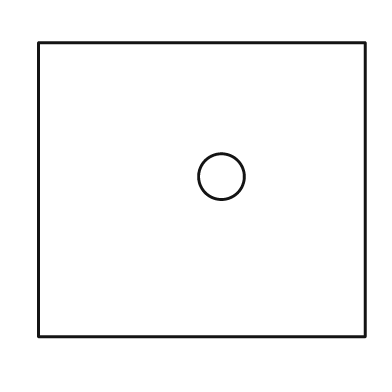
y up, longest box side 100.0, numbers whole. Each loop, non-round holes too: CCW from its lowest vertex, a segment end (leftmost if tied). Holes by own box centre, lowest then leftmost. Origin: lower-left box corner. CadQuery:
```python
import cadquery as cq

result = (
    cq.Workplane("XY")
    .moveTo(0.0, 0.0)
    .lineTo(100.0, 0.0)
    .lineTo(100.0, 90.0)
    .lineTo(0.0, 90.0)
    .close()
    .moveTo(56.0, 49.0)
    .circle(7.0)
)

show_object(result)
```